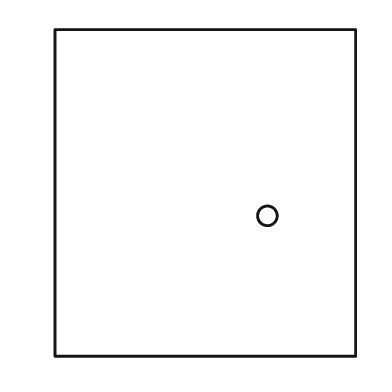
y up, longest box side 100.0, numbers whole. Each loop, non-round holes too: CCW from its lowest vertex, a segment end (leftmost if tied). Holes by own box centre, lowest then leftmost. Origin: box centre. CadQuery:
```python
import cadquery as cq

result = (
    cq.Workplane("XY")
    .moveTo(-46.0, -50.0)
    .lineTo(46.0, -50.0)
    .lineTo(46.0, 50.0)
    .lineTo(-46.0, 50.0)
    .close()
    .moveTo(19.0, -7.0)
    .circle(3.0)
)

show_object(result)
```